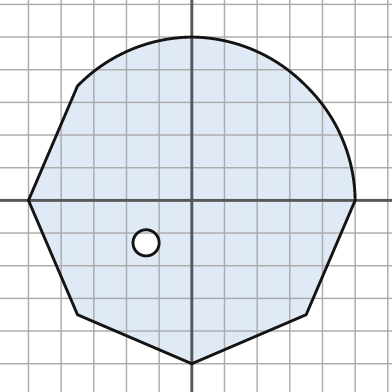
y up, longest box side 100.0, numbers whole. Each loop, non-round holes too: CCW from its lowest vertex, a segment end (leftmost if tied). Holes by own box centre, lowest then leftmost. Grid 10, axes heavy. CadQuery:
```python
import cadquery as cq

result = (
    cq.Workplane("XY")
    .moveTo(0.0, -50.0)
    .lineTo(35.0, -35.0)
    .lineTo(50.0, 0.0)
    .threePointArc((46.0, 19.0), (35.0, 35.0))
    .threePointArc((19.0, 46.0), (0.0, 50.0))
    .threePointArc((-19.0, 46.0), (-35.0, 35.0))
    .lineTo(-50.0, 0.0)
    .lineTo(-35.0, -35.0)
    .close()
    .moveTo(-14.0, -13.0)
    .circle(4.0)
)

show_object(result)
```